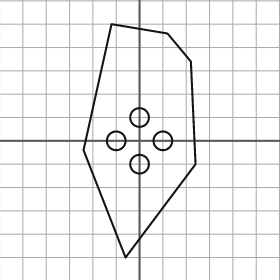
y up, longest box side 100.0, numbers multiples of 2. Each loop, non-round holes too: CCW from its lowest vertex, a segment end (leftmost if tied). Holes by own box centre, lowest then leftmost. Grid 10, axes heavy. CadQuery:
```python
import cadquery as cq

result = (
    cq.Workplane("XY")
    .moveTo(-6.0, -50.0)
    .lineTo(24.0, -10.0)
    .lineTo(22.0, 34.0)
    .lineTo(12.0, 46.0)
    .lineTo(-12.0, 50.0)
    .lineTo(-24.0, -4.0)
    .close()
    .moveTo(0.0, -10.0)
    .circle(4.0)
    .moveTo(-10.0, 0.0)
    .circle(4.0)
    .moveTo(10.0, 0.0)
    .circle(4.0)
    .moveTo(0.0, 10.0)
    .circle(4.0)
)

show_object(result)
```